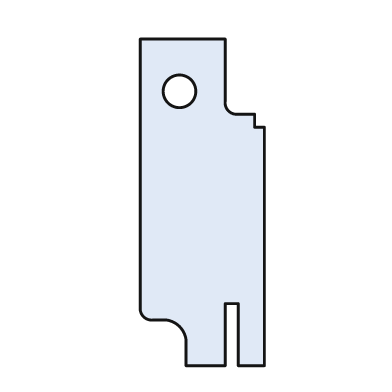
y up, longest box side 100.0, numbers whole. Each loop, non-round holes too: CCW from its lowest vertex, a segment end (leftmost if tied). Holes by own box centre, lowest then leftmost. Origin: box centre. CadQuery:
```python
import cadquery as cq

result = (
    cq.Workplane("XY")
    .moveTo(-5.0, -50.0)
    .lineTo(7.0, -50.0)
    .lineTo(7.0, -31.0)
    .lineTo(11.0, -31.0)
    .lineTo(11.0, -50.0)
    .lineTo(19.0, -50.0)
    .lineTo(19.0, 23.0)
    .lineTo(16.0, 23.0)
    .lineTo(16.0, 27.0)
    .lineTo(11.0, 27.0)
    .threePointArc((8.0, 28.0), (7.0, 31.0))
    .lineTo(7.0, 50.0)
    .lineTo(-19.0, 50.0)
    .lineTo(-19.0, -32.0)
    .threePointArc((-18.0, -35.0), (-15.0, -36.0))
    .lineTo(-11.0, -36.0)
    .threePointArc((-7.0, -38.0), (-5.0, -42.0))
    .close()
    .moveTo(-7.0, 34.0)
    .circle(5.0)
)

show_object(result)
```